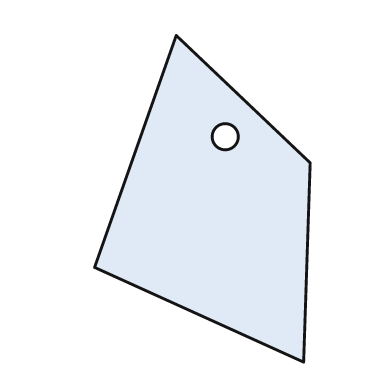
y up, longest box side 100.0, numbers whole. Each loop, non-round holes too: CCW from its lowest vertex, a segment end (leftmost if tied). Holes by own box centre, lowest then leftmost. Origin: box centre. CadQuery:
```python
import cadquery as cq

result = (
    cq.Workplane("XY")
    .moveTo(31.0, -50.0)
    .lineTo(33.0, 11.0)
    .lineTo(-8.0, 50.0)
    .lineTo(-33.0, -21.0)
    .close()
    .moveTo(7.0, 19.0)
    .circle(4.0)
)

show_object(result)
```